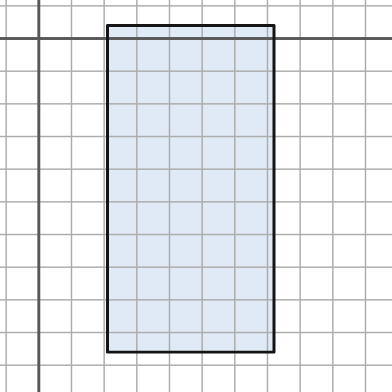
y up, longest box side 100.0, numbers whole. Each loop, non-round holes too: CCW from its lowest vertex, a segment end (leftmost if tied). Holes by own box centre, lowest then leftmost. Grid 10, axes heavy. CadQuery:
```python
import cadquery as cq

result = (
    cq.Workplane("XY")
    .moveTo(21.0, -96.0)
    .lineTo(72.0, -96.0)
    .lineTo(72.0, 4.0)
    .lineTo(21.0, 4.0)
    .close()
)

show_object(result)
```